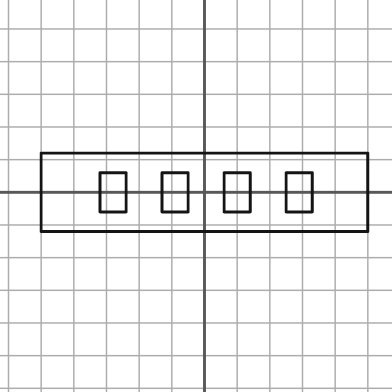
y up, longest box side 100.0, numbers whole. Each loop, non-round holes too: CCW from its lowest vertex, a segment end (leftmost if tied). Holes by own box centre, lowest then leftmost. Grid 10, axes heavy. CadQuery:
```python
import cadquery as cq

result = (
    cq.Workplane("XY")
    .moveTo(-50.0, -12.0)
    .lineTo(50.0, -12.0)
    .lineTo(50.0, 12.0)
    .lineTo(-50.0, 12.0)
    .close()
    .moveTo(-32.0, -6.0)
    .lineTo(-24.0, -6.0)
    .lineTo(-24.0, 6.0)
    .lineTo(-32.0, 6.0)
    .close()
    .moveTo(-13.0, -6.0)
    .lineTo(-5.0, -6.0)
    .lineTo(-5.0, 6.0)
    .lineTo(-13.0, 6.0)
    .close()
    .moveTo(6.0, -6.0)
    .lineTo(14.0, -6.0)
    .lineTo(14.0, 6.0)
    .lineTo(6.0, 6.0)
    .close()
    .moveTo(25.0, -6.0)
    .lineTo(33.0, -6.0)
    .lineTo(33.0, 6.0)
    .lineTo(25.0, 6.0)
    .close()
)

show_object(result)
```